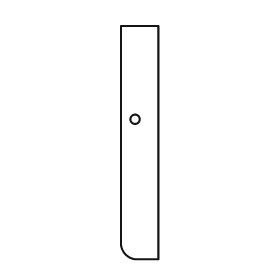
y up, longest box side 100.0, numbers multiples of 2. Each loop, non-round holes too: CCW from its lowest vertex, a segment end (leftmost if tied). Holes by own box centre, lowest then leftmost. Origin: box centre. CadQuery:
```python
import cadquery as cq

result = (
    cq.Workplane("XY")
    .moveTo(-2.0, -50.0)
    .lineTo(8.0, -50.0)
    .lineTo(8.0, 50.0)
    .lineTo(-8.0, 50.0)
    .lineTo(-8.0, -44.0)
    .threePointArc((-6.0, -48.0), (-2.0, -50.0))
    .close()
    .moveTo(-2.0, 10.0)
    .circle(2.0)
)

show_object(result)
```